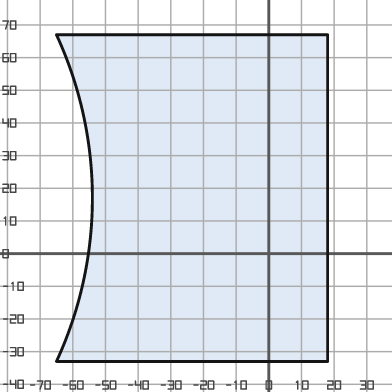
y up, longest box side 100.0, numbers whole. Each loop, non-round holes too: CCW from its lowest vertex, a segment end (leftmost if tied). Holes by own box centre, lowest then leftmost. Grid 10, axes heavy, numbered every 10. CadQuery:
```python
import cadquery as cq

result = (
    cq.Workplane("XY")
    .moveTo(-65.0, -33.0)
    .lineTo(18.0, -33.0)
    .lineTo(18.0, 67.0)
    .lineTo(-65.0, 67.0)
    .threePointArc((-54.0, 17.0), (-65.0, -33.0))
    .close()
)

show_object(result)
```